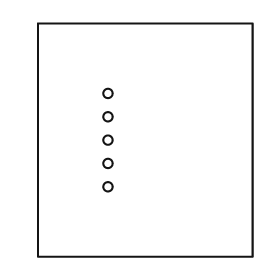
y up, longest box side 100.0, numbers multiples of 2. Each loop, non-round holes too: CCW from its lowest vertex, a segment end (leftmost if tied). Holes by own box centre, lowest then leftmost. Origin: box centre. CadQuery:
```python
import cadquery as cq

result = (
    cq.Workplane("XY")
    .moveTo(-46.0, -50.0)
    .lineTo(46.0, -50.0)
    .lineTo(46.0, 50.0)
    .lineTo(-46.0, 50.0)
    .close()
    .moveTo(-16.0, -20.0)
    .circle(2.0)
    .moveTo(-16.0, -10.0)
    .circle(2.0)
    .moveTo(-16.0, 0.0)
    .circle(2.0)
    .moveTo(-16.0, 10.0)
    .circle(2.0)
    .moveTo(-16.0, 20.0)
    .circle(2.0)
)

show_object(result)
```